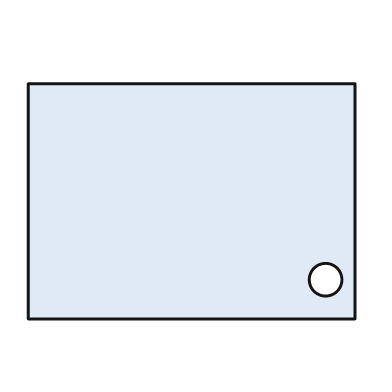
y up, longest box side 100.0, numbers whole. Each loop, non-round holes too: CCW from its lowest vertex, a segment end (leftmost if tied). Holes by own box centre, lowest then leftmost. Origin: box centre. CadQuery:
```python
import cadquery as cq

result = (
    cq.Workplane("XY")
    .moveTo(-50.0, -36.0)
    .lineTo(50.0, -36.0)
    .lineTo(50.0, 36.0)
    .lineTo(-50.0, 36.0)
    .close()
    .moveTo(41.0, -24.0)
    .circle(5.0)
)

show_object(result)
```